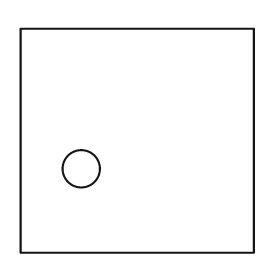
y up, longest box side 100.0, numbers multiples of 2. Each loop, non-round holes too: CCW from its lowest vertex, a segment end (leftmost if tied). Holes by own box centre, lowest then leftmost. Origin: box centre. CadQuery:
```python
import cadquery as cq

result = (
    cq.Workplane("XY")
    .moveTo(-50.0, -48.0)
    .lineTo(50.0, -48.0)
    .lineTo(50.0, 48.0)
    .lineTo(-50.0, 48.0)
    .close()
    .moveTo(-24.0, -12.0)
    .circle(8.0)
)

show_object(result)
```